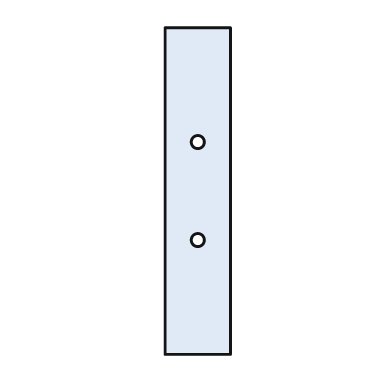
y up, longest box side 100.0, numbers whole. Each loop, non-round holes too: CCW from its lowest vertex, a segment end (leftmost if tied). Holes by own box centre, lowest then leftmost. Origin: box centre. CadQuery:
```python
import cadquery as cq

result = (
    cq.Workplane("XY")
    .moveTo(-10.0, -50.0)
    .lineTo(10.0, -50.0)
    .lineTo(10.0, 50.0)
    .lineTo(-10.0, 50.0)
    .close()
    .moveTo(0.0, -15.0)
    .circle(2.0)
    .moveTo(0.0, 15.0)
    .circle(2.0)
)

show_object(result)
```